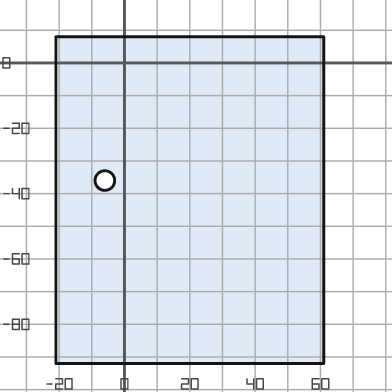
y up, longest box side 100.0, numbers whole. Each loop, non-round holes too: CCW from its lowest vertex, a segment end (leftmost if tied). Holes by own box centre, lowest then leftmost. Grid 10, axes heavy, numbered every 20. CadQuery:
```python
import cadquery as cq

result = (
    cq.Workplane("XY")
    .moveTo(-21.0, -92.0)
    .lineTo(61.0, -92.0)
    .lineTo(61.0, 8.0)
    .lineTo(-21.0, 8.0)
    .close()
    .moveTo(-6.0, -36.0)
    .circle(3.0)
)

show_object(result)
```